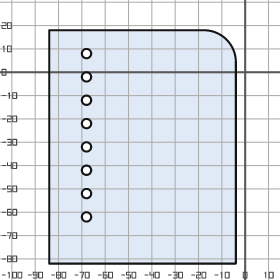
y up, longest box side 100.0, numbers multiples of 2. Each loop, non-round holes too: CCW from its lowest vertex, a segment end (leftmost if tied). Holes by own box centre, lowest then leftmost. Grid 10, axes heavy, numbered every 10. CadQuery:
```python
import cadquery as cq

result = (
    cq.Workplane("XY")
    .moveTo(-84.0, -82.0)
    .lineTo(-4.0, -82.0)
    .lineTo(-4.0, 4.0)
    .threePointArc((-8.0, 14.0), (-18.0, 18.0))
    .lineTo(-84.0, 18.0)
    .close()
    .moveTo(-68.0, -62.0)
    .circle(2.0)
    .moveTo(-68.0, -52.0)
    .circle(2.0)
    .moveTo(-68.0, -42.0)
    .circle(2.0)
    .moveTo(-68.0, -32.0)
    .circle(2.0)
    .moveTo(-68.0, -22.0)
    .circle(2.0)
    .moveTo(-68.0, -12.0)
    .circle(2.0)
    .moveTo(-68.0, -2.0)
    .circle(2.0)
    .moveTo(-68.0, 8.0)
    .circle(2.0)
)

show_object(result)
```